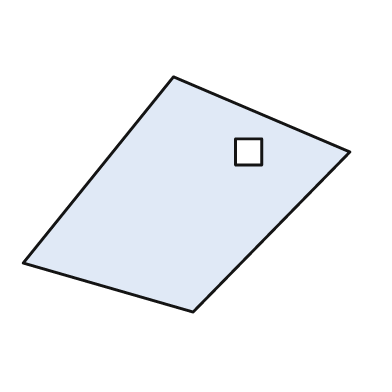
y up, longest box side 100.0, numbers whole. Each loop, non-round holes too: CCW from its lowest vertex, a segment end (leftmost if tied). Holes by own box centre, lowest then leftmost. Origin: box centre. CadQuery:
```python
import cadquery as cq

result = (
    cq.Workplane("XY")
    .moveTo(2.0, -36.0)
    .lineTo(50.0, 13.0)
    .lineTo(-4.0, 36.0)
    .lineTo(-50.0, -21.0)
    .close()
    .moveTo(15.0, 9.0)
    .lineTo(23.0, 9.0)
    .lineTo(23.0, 17.0)
    .lineTo(15.0, 17.0)
    .close()
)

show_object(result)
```